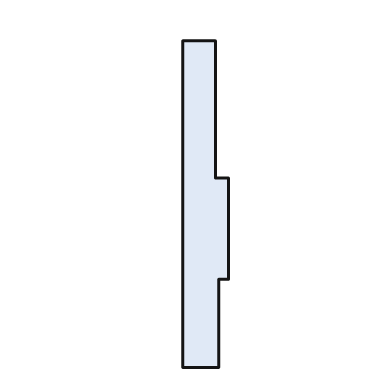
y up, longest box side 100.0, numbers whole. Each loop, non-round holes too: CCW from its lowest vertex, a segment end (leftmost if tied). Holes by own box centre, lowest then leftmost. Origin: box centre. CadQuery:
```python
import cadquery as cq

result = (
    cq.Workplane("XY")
    .moveTo(-7.0, -50.0)
    .lineTo(4.0, -50.0)
    .lineTo(4.0, -23.0)
    .lineTo(7.0, -23.0)
    .lineTo(7.0, 8.0)
    .lineTo(3.0, 8.0)
    .lineTo(3.0, 50.0)
    .lineTo(-7.0, 50.0)
    .close()
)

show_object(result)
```